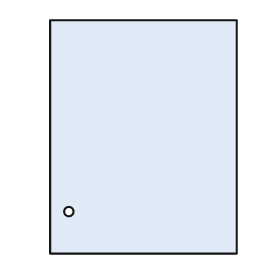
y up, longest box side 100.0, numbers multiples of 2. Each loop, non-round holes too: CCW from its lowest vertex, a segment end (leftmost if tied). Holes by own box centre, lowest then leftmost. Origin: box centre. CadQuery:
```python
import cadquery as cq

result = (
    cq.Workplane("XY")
    .moveTo(-40.0, -50.0)
    .lineTo(40.0, -50.0)
    .lineTo(40.0, 50.0)
    .lineTo(-40.0, 50.0)
    .close()
    .moveTo(-32.0, -32.0)
    .circle(2.0)
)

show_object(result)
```